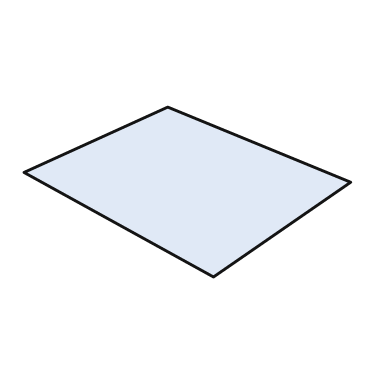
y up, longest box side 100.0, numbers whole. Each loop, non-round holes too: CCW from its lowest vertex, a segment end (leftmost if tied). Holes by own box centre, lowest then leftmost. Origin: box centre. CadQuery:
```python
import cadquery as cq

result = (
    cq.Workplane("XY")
    .moveTo(8.0, -26.0)
    .lineTo(50.0, 3.0)
    .lineTo(-6.0, 26.0)
    .lineTo(-50.0, 6.0)
    .close()
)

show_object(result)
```